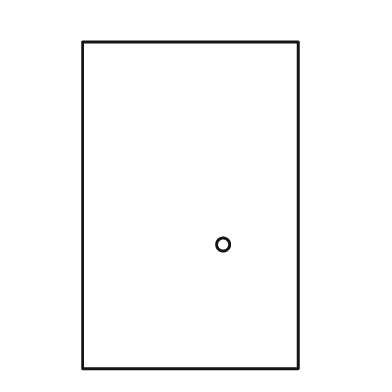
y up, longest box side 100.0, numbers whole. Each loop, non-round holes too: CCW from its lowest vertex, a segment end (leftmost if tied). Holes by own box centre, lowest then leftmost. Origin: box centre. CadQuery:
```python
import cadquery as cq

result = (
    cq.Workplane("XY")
    .moveTo(-33.0, -50.0)
    .lineTo(33.0, -50.0)
    .lineTo(33.0, 50.0)
    .lineTo(-33.0, 50.0)
    .close()
    .moveTo(10.0, -12.0)
    .circle(2.0)
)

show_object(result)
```